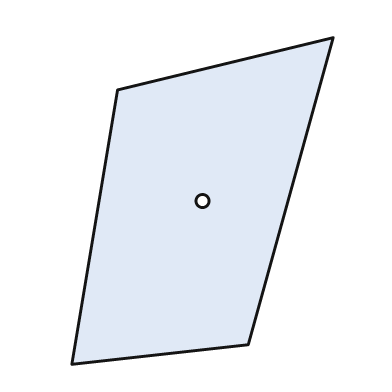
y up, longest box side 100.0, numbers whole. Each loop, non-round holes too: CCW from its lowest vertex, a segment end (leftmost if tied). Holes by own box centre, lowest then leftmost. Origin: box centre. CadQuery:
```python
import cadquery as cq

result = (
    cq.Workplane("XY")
    .moveTo(-40.0, -50.0)
    .lineTo(14.0, -44.0)
    .lineTo(40.0, 50.0)
    .lineTo(-26.0, 34.0)
    .close()
    .moveTo(0.0, 0.0)
    .circle(2.0)
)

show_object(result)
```